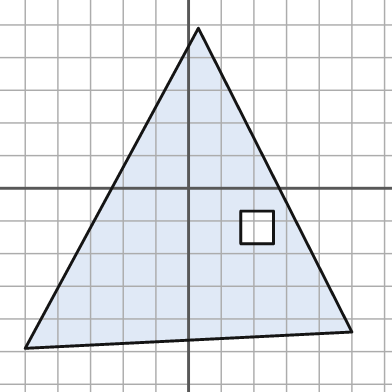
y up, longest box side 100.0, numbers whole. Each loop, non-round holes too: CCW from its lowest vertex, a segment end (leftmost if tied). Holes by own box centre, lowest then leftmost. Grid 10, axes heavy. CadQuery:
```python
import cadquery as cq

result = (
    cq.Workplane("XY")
    .moveTo(-50.0, -49.0)
    .lineTo(50.0, -44.0)
    .lineTo(3.0, 49.0)
    .close()
    .moveTo(16.0, -17.0)
    .lineTo(26.0, -17.0)
    .lineTo(26.0, -7.0)
    .lineTo(16.0, -7.0)
    .close()
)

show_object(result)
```